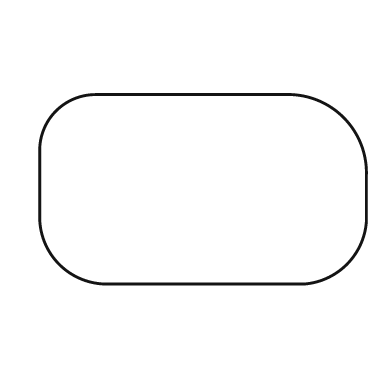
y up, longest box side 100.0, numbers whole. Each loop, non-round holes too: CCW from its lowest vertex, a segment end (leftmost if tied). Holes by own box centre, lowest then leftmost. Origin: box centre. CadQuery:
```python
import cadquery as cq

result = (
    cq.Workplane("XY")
    .moveTo(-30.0, -29.0)
    .lineTo(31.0, -29.0)
    .threePointArc((44.0, -23.0), (50.0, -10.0))
    .lineTo(50.0, 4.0)
    .threePointArc((43.0, 22.0), (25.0, 29.0))
    .lineTo(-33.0, 29.0)
    .threePointArc((-45.0, 24.0), (-50.0, 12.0))
    .lineTo(-50.0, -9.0)
    .threePointArc((-44.0, -23.0), (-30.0, -29.0))
    .close()
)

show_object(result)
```